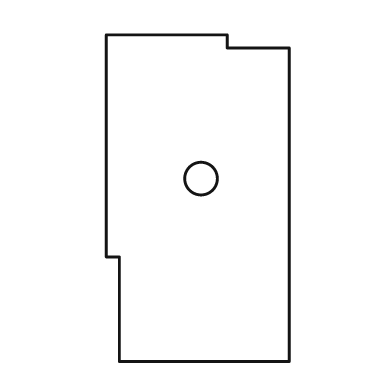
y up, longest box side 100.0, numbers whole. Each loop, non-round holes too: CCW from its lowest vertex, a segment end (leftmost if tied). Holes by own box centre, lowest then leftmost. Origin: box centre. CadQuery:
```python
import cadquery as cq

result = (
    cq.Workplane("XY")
    .moveTo(-24.0, -50.0)
    .lineTo(28.0, -50.0)
    .lineTo(28.0, 46.0)
    .lineTo(9.0, 46.0)
    .lineTo(9.0, 50.0)
    .lineTo(-28.0, 50.0)
    .lineTo(-28.0, -18.0)
    .lineTo(-24.0, -18.0)
    .close()
    .moveTo(1.0, 6.0)
    .circle(5.0)
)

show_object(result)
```